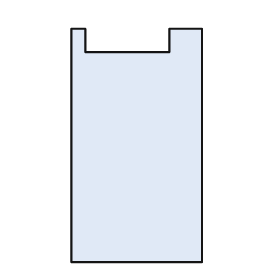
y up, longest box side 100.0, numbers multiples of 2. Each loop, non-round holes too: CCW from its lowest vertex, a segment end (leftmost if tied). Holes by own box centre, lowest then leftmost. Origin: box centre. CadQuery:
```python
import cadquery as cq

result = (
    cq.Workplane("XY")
    .moveTo(-28.0, -50.0)
    .lineTo(28.0, -50.0)
    .lineTo(28.0, 50.0)
    .lineTo(14.0, 50.0)
    .lineTo(14.0, 40.0)
    .lineTo(-22.0, 40.0)
    .lineTo(-22.0, 50.0)
    .lineTo(-28.0, 50.0)
    .close()
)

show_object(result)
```